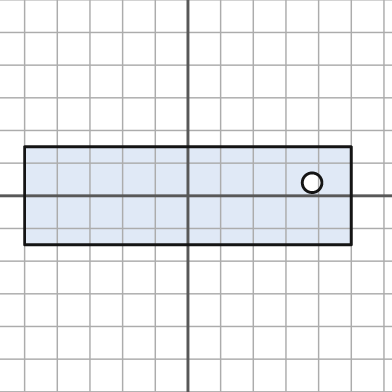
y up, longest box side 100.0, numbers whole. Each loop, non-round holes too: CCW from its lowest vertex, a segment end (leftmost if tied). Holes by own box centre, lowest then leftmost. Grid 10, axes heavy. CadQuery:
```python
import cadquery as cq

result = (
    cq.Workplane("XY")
    .moveTo(-50.0, -15.0)
    .lineTo(50.0, -15.0)
    .lineTo(50.0, 15.0)
    .lineTo(-50.0, 15.0)
    .close()
    .moveTo(38.0, 4.0)
    .circle(3.0)
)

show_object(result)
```